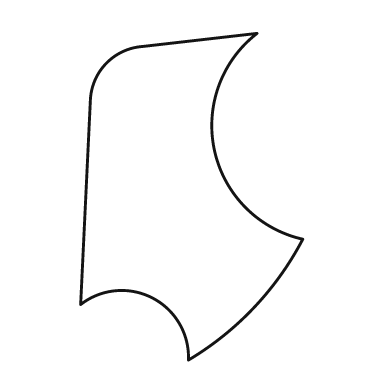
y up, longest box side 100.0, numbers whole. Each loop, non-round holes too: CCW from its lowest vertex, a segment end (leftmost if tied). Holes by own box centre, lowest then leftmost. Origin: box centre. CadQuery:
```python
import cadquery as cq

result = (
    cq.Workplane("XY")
    .moveTo(-1.0, -50.0)
    .threePointArc((19.0, -34.0), (34.0, -13.0))
    .threePointArc((7.0, 14.0), (20.0, 50.0))
    .lineTo(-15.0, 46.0)
    .threePointArc((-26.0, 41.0), (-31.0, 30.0))
    .lineTo(-34.0, -33.0)
    .threePointArc((-12.0, -31.0), (-1.0, -50.0))
    .close()
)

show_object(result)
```